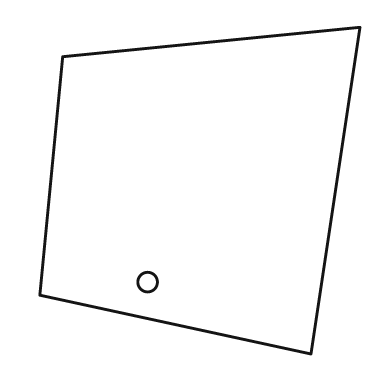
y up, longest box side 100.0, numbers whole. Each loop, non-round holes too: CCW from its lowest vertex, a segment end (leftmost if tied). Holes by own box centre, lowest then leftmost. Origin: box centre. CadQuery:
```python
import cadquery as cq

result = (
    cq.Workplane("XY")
    .moveTo(34.0, -50.0)
    .lineTo(49.0, 50.0)
    .lineTo(-42.0, 41.0)
    .lineTo(-49.0, -32.0)
    .close()
    .moveTo(-16.0, -28.0)
    .circle(3.0)
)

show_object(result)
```